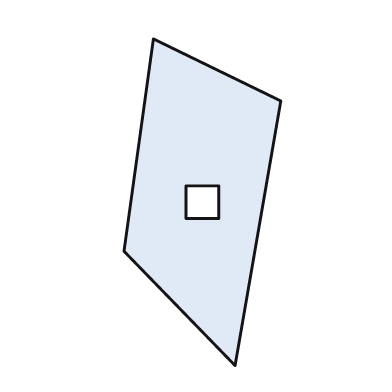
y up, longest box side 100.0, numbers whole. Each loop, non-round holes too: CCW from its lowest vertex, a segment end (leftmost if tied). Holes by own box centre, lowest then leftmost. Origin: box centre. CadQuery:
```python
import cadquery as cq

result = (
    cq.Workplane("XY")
    .moveTo(10.0, -50.0)
    .lineTo(24.0, 31.0)
    .lineTo(-15.0, 50.0)
    .lineTo(-24.0, -15.0)
    .close()
    .moveTo(-5.0, -5.0)
    .lineTo(5.0, -5.0)
    .lineTo(5.0, 5.0)
    .lineTo(-5.0, 5.0)
    .close()
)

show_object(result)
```